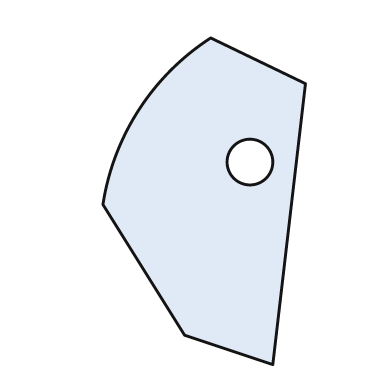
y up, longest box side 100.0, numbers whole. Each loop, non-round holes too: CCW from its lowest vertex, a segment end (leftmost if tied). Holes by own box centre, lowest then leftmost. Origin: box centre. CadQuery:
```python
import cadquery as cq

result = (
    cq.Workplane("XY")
    .moveTo(21.0, -50.0)
    .lineTo(31.0, 36.0)
    .lineTo(2.0, 50.0)
    .threePointArc((-20.0, 28.0), (-31.0, -1.0))
    .lineTo(-6.0, -41.0)
    .close()
    .moveTo(14.0, 12.0)
    .circle(7.0)
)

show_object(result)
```